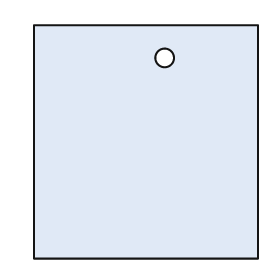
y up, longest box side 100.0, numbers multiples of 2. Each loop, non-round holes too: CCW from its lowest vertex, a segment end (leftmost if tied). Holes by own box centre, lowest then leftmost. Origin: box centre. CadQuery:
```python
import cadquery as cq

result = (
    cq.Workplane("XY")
    .moveTo(-48.0, -50.0)
    .lineTo(48.0, -50.0)
    .lineTo(48.0, 50.0)
    .lineTo(-48.0, 50.0)
    .close()
    .moveTo(8.0, 36.0)
    .circle(4.0)
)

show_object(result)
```